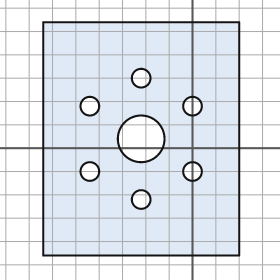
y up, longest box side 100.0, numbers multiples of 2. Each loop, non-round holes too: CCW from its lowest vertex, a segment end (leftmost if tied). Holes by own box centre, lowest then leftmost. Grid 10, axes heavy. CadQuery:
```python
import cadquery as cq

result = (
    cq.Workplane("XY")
    .moveTo(-64.0, -46.0)
    .lineTo(20.0, -46.0)
    .lineTo(20.0, 54.0)
    .lineTo(-64.0, 54.0)
    .close()
    .moveTo(-22.0, -22.0)
    .circle(4.0)
    .moveTo(-44.0, -10.0)
    .circle(4.0)
    .moveTo(0.0, -10.0)
    .circle(4.0)
    .moveTo(-22.0, 4.0)
    .circle(10.0)
    .moveTo(-44.0, 18.0)
    .circle(4.0)
    .moveTo(0.0, 18.0)
    .circle(4.0)
    .moveTo(-22.0, 30.0)
    .circle(4.0)
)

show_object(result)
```